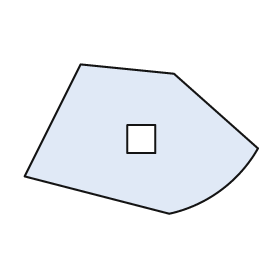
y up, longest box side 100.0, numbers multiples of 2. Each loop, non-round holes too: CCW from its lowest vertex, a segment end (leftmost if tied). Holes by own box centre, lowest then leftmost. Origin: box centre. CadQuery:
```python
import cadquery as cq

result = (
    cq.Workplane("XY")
    .moveTo(12.0, -32.0)
    .threePointArc((34.0, -22.0), (50.0, -4.0))
    .lineTo(14.0, 28.0)
    .lineTo(-26.0, 32.0)
    .lineTo(-50.0, -16.0)
    .close()
    .moveTo(-6.0, -6.0)
    .lineTo(6.0, -6.0)
    .lineTo(6.0, 6.0)
    .lineTo(-6.0, 6.0)
    .close()
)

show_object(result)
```